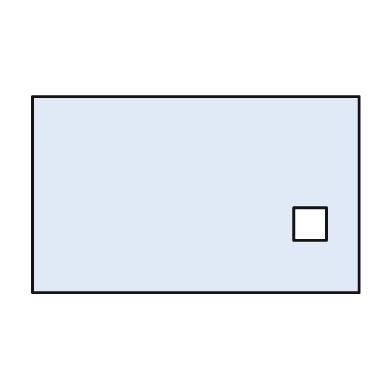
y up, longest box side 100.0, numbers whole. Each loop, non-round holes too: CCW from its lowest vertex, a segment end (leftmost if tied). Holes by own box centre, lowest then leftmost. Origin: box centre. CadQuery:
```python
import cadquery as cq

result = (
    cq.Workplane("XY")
    .moveTo(-50.0, -30.0)
    .lineTo(50.0, -30.0)
    .lineTo(50.0, 30.0)
    .lineTo(-50.0, 30.0)
    .close()
    .moveTo(30.0, -14.0)
    .lineTo(40.0, -14.0)
    .lineTo(40.0, -4.0)
    .lineTo(30.0, -4.0)
    .close()
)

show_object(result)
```